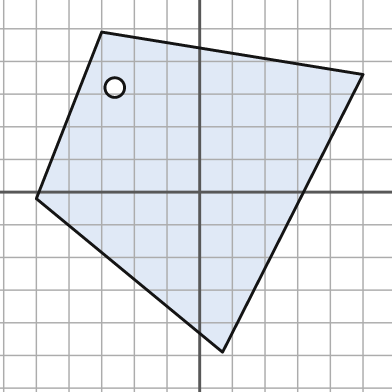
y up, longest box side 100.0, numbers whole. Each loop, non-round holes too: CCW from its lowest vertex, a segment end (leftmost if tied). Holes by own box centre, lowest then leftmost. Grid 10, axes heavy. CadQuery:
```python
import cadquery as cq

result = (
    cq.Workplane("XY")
    .moveTo(7.0, -49.0)
    .lineTo(50.0, 36.0)
    .lineTo(-30.0, 49.0)
    .lineTo(-50.0, -2.0)
    .close()
    .moveTo(-26.0, 32.0)
    .circle(3.0)
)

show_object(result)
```